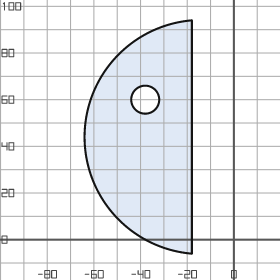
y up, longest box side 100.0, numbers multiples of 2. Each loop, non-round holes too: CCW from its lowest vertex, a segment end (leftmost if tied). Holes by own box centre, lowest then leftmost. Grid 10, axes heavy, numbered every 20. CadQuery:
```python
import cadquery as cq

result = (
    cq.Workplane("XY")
    .moveTo(-18.0, -6.0)
    .lineTo(-18.0, 94.0)
    .threePointArc((-64.0, 44.0), (-18.0, -6.0))
    .close()
    .moveTo(-38.0, 60.0)
    .circle(6.0)
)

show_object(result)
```